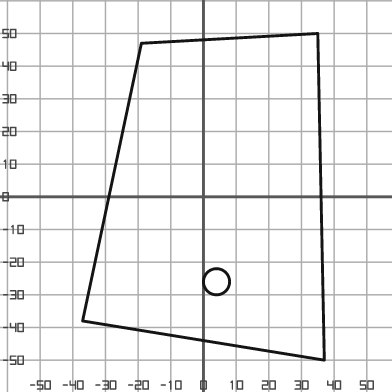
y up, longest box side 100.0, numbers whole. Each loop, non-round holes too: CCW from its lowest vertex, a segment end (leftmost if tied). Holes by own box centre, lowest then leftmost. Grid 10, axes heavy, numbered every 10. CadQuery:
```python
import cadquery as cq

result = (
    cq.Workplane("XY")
    .moveTo(37.0, -50.0)
    .lineTo(35.0, 50.0)
    .lineTo(-19.0, 47.0)
    .lineTo(-37.0, -38.0)
    .close()
    .moveTo(4.0, -26.0)
    .circle(4.0)
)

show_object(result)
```